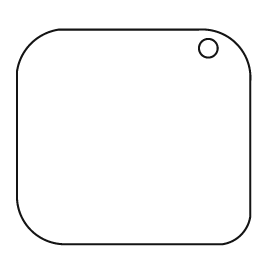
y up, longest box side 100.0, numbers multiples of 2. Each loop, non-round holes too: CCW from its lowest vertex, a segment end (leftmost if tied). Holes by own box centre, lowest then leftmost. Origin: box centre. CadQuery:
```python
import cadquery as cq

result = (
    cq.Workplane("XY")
    .moveTo(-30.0, -46.0)
    .lineTo(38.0, -46.0)
    .threePointArc((46.0, -42.0), (50.0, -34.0))
    .lineTo(50.0, 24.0)
    .threePointArc((44.0, 40.0), (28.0, 46.0))
    .lineTo(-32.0, 46.0)
    .threePointArc((-44.0, 40.0), (-50.0, 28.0))
    .lineTo(-50.0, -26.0)
    .threePointArc((-44.0, -40.0), (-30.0, -46.0))
    .close()
    .moveTo(32.0, 38.0)
    .circle(4.0)
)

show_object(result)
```